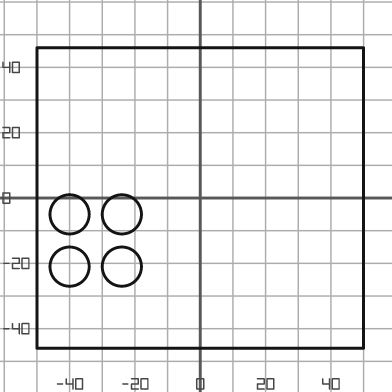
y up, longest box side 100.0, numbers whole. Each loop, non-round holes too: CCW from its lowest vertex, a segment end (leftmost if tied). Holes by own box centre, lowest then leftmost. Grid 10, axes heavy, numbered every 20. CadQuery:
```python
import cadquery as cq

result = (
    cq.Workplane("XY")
    .moveTo(-50.0, -46.0)
    .lineTo(50.0, -46.0)
    .lineTo(50.0, 46.0)
    .lineTo(-50.0, 46.0)
    .close()
    .moveTo(-40.0, -21.0)
    .circle(6.0)
    .moveTo(-24.0, -21.0)
    .circle(6.0)
    .moveTo(-40.0, -5.0)
    .circle(6.0)
    .moveTo(-24.0, -5.0)
    .circle(6.0)
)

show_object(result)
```